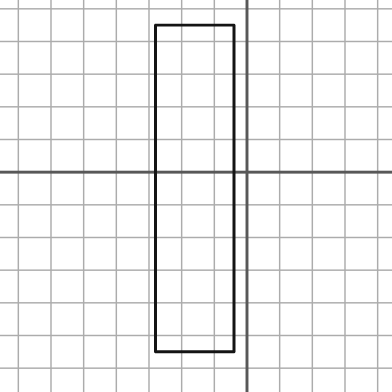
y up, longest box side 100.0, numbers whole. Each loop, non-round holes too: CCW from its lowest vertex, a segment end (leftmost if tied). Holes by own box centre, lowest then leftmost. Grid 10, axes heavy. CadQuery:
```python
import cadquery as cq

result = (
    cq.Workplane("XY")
    .moveTo(-28.0, -55.0)
    .lineTo(-4.0, -55.0)
    .lineTo(-4.0, 45.0)
    .lineTo(-28.0, 45.0)
    .close()
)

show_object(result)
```